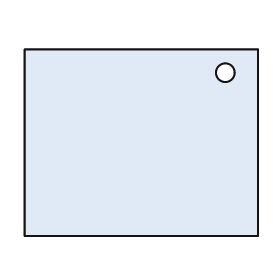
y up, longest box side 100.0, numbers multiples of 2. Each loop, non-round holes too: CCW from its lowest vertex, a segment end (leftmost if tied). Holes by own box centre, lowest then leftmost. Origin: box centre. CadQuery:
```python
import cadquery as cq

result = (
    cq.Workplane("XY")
    .moveTo(-50.0, -40.0)
    .lineTo(50.0, -40.0)
    .lineTo(50.0, 40.0)
    .lineTo(-50.0, 40.0)
    .close()
    .moveTo(36.0, 30.0)
    .circle(4.0)
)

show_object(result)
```